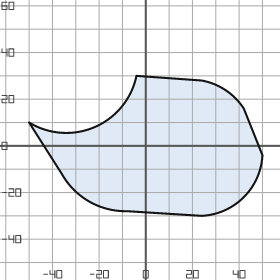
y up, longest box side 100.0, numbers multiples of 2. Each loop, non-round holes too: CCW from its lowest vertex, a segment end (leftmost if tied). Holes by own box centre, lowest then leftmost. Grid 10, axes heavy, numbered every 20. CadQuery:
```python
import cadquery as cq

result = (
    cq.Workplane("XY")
    .moveTo(24.0, -30.0)
    .threePointArc((42.0, -22.0), (50.0, -4.0))
    .lineTo(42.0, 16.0)
    .threePointArc((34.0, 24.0), (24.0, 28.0))
    .lineTo(-4.0, 30.0)
    .threePointArc((-22.0, 8.0), (-50.0, 10.0))
    .lineTo(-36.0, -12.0)
    .threePointArc((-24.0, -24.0), (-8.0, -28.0))
    .close()
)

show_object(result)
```